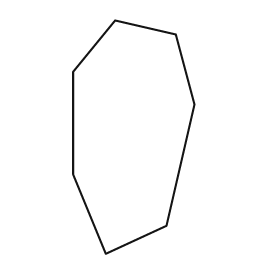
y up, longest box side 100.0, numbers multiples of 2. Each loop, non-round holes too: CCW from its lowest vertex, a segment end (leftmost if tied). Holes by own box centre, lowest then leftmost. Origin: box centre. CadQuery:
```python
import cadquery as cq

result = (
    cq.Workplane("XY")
    .moveTo(-12.0, -50.0)
    .lineTo(14.0, -38.0)
    .lineTo(26.0, 14.0)
    .lineTo(18.0, 44.0)
    .lineTo(-8.0, 50.0)
    .lineTo(-26.0, 28.0)
    .lineTo(-26.0, -16.0)
    .close()
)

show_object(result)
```